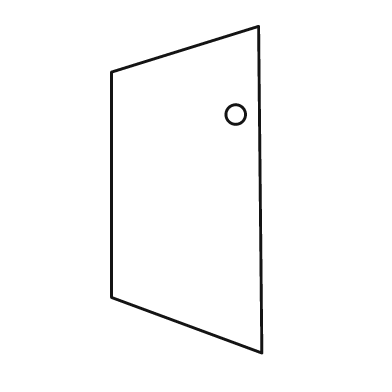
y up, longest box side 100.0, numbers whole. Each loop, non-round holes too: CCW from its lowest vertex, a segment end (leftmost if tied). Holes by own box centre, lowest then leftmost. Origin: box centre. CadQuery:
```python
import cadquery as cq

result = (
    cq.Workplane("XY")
    .moveTo(23.0, -50.0)
    .lineTo(22.0, 50.0)
    .lineTo(-23.0, 36.0)
    .lineTo(-23.0, -33.0)
    .close()
    .moveTo(15.0, 23.0)
    .circle(3.0)
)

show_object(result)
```